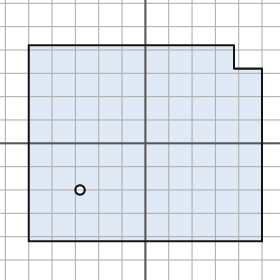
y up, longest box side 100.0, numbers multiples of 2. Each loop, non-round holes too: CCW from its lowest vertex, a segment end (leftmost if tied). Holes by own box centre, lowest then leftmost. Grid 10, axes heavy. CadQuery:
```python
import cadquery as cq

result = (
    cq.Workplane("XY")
    .moveTo(-50.0, -42.0)
    .lineTo(50.0, -42.0)
    .lineTo(50.0, 32.0)
    .lineTo(38.0, 32.0)
    .lineTo(38.0, 42.0)
    .lineTo(-50.0, 42.0)
    .close()
    .moveTo(-28.0, -20.0)
    .circle(2.0)
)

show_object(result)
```